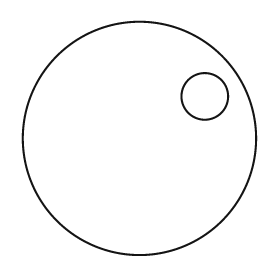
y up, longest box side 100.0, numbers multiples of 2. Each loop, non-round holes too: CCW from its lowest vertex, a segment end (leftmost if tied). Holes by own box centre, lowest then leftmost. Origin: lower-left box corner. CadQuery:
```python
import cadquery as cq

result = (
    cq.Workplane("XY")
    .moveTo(50.0, 50.0)
    .circle(50.0)
    .moveTo(78.0, 68.0)
    .circle(10.0)
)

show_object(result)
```